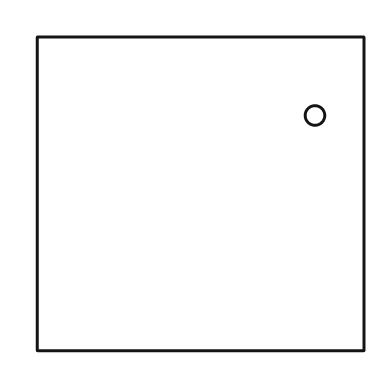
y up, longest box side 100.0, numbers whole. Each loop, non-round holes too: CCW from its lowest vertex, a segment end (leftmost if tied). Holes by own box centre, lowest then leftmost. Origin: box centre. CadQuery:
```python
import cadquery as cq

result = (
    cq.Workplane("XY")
    .moveTo(-50.0, -48.0)
    .lineTo(50.0, -48.0)
    .lineTo(50.0, 48.0)
    .lineTo(-50.0, 48.0)
    .close()
    .moveTo(35.0, 24.0)
    .circle(3.0)
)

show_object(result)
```